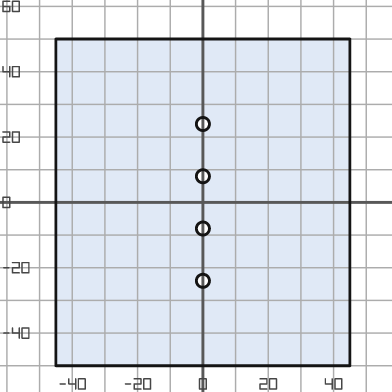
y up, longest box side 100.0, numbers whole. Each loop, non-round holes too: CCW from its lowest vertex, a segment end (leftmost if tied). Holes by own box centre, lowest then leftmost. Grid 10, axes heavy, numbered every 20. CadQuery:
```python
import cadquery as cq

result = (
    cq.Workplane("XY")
    .moveTo(-45.0, -50.0)
    .lineTo(45.0, -50.0)
    .lineTo(45.0, 50.0)
    .lineTo(-45.0, 50.0)
    .close()
    .moveTo(0.0, -24.0)
    .circle(2.0)
    .moveTo(0.0, -8.0)
    .circle(2.0)
    .moveTo(0.0, 8.0)
    .circle(2.0)
    .moveTo(0.0, 24.0)
    .circle(2.0)
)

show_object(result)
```